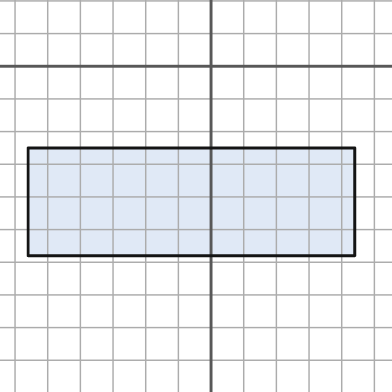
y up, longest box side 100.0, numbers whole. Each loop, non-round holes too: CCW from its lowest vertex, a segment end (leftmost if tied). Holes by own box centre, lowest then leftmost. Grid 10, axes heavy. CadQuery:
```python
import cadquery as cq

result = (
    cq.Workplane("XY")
    .moveTo(-56.0, -58.0)
    .lineTo(44.0, -58.0)
    .lineTo(44.0, -25.0)
    .lineTo(-56.0, -25.0)
    .close()
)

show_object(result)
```